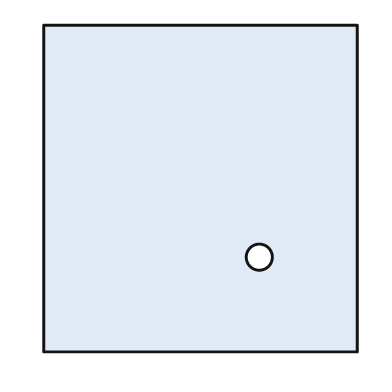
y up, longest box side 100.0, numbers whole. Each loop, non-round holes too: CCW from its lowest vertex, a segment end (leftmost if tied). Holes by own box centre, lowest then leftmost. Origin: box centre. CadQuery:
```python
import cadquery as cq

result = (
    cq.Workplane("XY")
    .moveTo(-48.0, -50.0)
    .lineTo(48.0, -50.0)
    .lineTo(48.0, 50.0)
    .lineTo(-48.0, 50.0)
    .close()
    .moveTo(18.0, -21.0)
    .circle(4.0)
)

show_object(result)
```